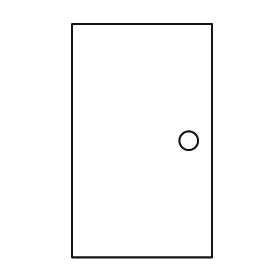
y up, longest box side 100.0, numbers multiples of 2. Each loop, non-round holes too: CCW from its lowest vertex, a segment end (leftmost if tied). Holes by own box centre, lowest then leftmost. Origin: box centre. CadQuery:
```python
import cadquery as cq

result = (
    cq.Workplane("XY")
    .moveTo(-30.0, -50.0)
    .lineTo(30.0, -50.0)
    .lineTo(30.0, 50.0)
    .lineTo(-30.0, 50.0)
    .close()
    .moveTo(20.0, 0.0)
    .circle(4.0)
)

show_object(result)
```